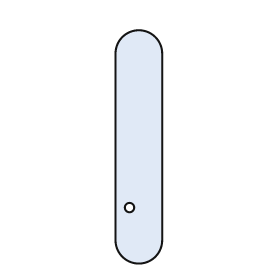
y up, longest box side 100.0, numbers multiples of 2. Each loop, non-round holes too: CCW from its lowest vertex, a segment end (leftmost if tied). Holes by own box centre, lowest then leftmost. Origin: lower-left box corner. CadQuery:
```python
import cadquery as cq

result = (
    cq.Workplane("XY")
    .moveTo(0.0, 10.0)
    .threePointArc((10.0, 0.0), (20.0, 10.0))
    .lineTo(20.0, 90.0)
    .threePointArc((10.0, 100.0), (0.0, 90.0))
    .close()
    .moveTo(6.0, 24.0)
    .circle(2.0)
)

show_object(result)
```